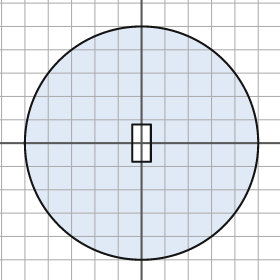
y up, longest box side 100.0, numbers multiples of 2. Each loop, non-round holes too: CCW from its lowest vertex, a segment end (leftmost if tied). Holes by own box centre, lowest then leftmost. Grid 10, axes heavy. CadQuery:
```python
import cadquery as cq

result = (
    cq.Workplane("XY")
    .moveTo(0.0, 0.0)
    .circle(50.0)
    .moveTo(-4.0, -8.0)
    .lineTo(4.0, -8.0)
    .lineTo(4.0, 8.0)
    .lineTo(-4.0, 8.0)
    .close()
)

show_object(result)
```